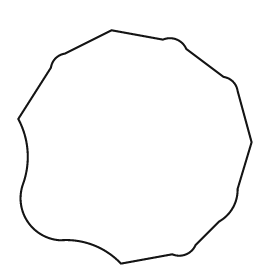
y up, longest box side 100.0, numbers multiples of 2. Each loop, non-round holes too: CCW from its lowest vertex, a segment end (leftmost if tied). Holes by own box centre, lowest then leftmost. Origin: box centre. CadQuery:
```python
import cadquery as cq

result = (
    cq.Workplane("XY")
    .moveTo(-6.0, -50.0)
    .lineTo(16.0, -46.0)
    .threePointArc((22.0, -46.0), (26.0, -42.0))
    .lineTo(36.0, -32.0)
    .threePointArc((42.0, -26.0), (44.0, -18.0))
    .lineTo(50.0, 2.0)
    .lineTo(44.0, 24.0)
    .threePointArc((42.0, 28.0), (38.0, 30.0))
    .lineTo(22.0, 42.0)
    .threePointArc((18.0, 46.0), (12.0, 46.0))
    .lineTo(-10.0, 50.0)
    .lineTo(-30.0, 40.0)
    .threePointArc((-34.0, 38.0), (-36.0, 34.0))
    .lineTo(-50.0, 12.0)
    .threePointArc((-46.0, -2.0), (-48.0, -16.0))
    .threePointArc((-46.0, -32.0), (-32.0, -40.0))
    .threePointArc((-18.0, -42.0), (-6.0, -50.0))
    .close()
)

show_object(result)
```